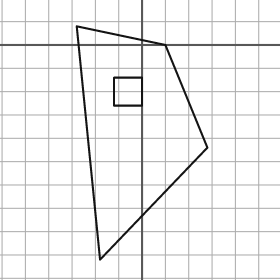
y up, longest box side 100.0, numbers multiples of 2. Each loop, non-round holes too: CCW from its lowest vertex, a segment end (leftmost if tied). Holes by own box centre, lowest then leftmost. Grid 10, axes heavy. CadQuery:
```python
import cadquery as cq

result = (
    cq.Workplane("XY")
    .moveTo(-18.0, -92.0)
    .lineTo(28.0, -44.0)
    .lineTo(10.0, 0.0)
    .lineTo(-28.0, 8.0)
    .close()
    .moveTo(-12.0, -26.0)
    .lineTo(0.0, -26.0)
    .lineTo(0.0, -14.0)
    .lineTo(-12.0, -14.0)
    .close()
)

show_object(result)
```